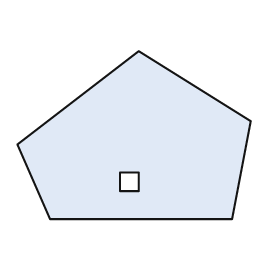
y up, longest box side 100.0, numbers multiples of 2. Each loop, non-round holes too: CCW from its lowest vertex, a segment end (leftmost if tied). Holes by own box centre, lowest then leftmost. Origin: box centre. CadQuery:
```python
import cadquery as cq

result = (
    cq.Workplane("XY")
    .moveTo(-36.0, -36.0)
    .lineTo(42.0, -36.0)
    .lineTo(50.0, 6.0)
    .lineTo(2.0, 36.0)
    .lineTo(-50.0, -4.0)
    .close()
    .moveTo(-6.0, -24.0)
    .lineTo(2.0, -24.0)
    .lineTo(2.0, -16.0)
    .lineTo(-6.0, -16.0)
    .close()
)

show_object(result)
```